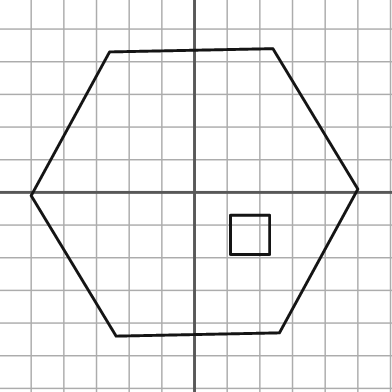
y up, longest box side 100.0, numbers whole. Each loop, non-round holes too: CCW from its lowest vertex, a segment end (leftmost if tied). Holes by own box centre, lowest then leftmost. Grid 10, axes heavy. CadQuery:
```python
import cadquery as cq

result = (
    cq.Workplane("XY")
    .moveTo(-24.0, -44.0)
    .lineTo(26.0, -43.0)
    .lineTo(50.0, 1.0)
    .lineTo(24.0, 44.0)
    .lineTo(-26.0, 43.0)
    .lineTo(-50.0, -1.0)
    .close()
    .moveTo(11.0, -19.0)
    .lineTo(23.0, -19.0)
    .lineTo(23.0, -7.0)
    .lineTo(11.0, -7.0)
    .close()
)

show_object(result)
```